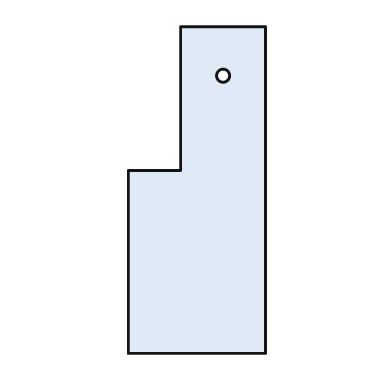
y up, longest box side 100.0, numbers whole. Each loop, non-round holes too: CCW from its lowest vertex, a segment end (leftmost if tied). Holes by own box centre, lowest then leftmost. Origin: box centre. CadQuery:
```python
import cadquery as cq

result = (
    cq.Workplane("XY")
    .moveTo(-21.0, -50.0)
    .lineTo(21.0, -50.0)
    .lineTo(21.0, 50.0)
    .lineTo(-5.0, 50.0)
    .lineTo(-5.0, 6.0)
    .lineTo(-21.0, 6.0)
    .close()
    .moveTo(8.0, 35.0)
    .circle(2.0)
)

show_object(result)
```